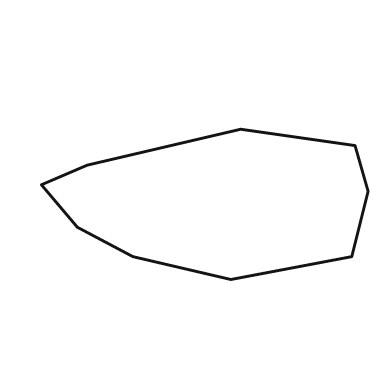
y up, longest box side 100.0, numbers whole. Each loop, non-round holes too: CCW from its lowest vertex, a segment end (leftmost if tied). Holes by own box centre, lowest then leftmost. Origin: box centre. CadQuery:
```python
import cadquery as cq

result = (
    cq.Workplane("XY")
    .moveTo(8.0, -23.0)
    .lineTo(45.0, -16.0)
    .lineTo(50.0, 4.0)
    .lineTo(46.0, 18.0)
    .lineTo(11.0, 23.0)
    .lineTo(-36.0, 12.0)
    .lineTo(-50.0, 6.0)
    .lineTo(-39.0, -7.0)
    .lineTo(-22.0, -16.0)
    .close()
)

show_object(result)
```